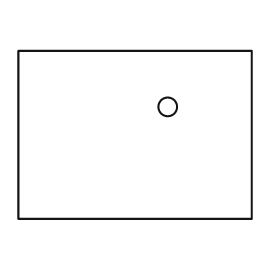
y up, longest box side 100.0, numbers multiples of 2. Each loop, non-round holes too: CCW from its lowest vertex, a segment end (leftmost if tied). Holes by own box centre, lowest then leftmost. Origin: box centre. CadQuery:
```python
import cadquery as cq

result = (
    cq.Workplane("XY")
    .moveTo(-50.0, -36.0)
    .lineTo(50.0, -36.0)
    .lineTo(50.0, 36.0)
    .lineTo(-50.0, 36.0)
    .close()
    .moveTo(14.0, 12.0)
    .circle(4.0)
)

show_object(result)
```